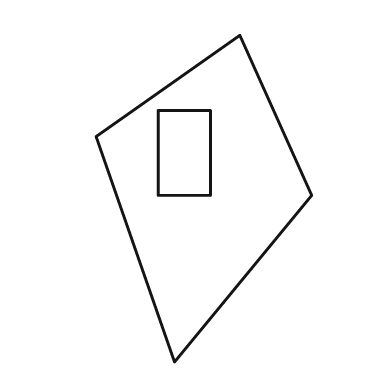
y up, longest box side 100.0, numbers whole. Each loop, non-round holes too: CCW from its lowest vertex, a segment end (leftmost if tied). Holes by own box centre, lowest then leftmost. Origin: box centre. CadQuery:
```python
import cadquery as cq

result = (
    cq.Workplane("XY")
    .moveTo(-9.0, -50.0)
    .lineTo(33.0, 1.0)
    .lineTo(11.0, 50.0)
    .lineTo(-33.0, 19.0)
    .close()
    .moveTo(-14.0, 1.0)
    .lineTo(2.0, 1.0)
    .lineTo(2.0, 27.0)
    .lineTo(-14.0, 27.0)
    .close()
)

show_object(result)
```